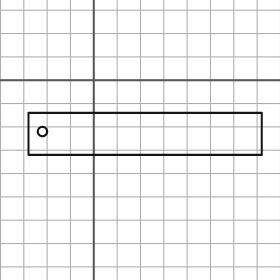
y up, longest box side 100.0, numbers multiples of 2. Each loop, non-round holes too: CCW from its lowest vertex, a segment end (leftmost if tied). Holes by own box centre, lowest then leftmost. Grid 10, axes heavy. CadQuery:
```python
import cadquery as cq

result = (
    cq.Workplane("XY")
    .moveTo(-28.0, -32.0)
    .lineTo(72.0, -32.0)
    .lineTo(72.0, -14.0)
    .lineTo(-28.0, -14.0)
    .close()
    .moveTo(-22.0, -22.0)
    .circle(2.0)
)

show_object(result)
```